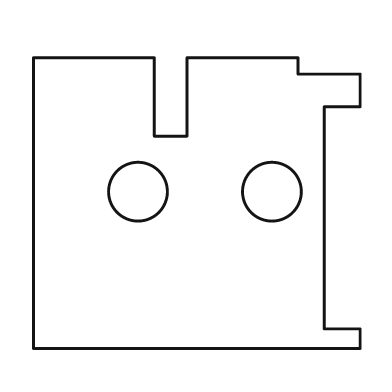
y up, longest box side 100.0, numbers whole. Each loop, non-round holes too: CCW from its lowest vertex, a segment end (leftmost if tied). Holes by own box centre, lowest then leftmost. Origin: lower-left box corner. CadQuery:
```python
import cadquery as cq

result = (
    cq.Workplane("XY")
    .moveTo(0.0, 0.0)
    .lineTo(100.0, 0.0)
    .lineTo(100.0, 6.0)
    .lineTo(89.0, 6.0)
    .lineTo(89.0, 74.0)
    .lineTo(100.0, 74.0)
    .lineTo(100.0, 84.0)
    .lineTo(81.0, 84.0)
    .lineTo(81.0, 89.0)
    .lineTo(47.0, 89.0)
    .lineTo(47.0, 65.0)
    .lineTo(37.0, 65.0)
    .lineTo(37.0, 89.0)
    .lineTo(0.0, 89.0)
    .close()
    .moveTo(32.0, 48.0)
    .circle(9.0)
    .moveTo(73.0, 48.0)
    .circle(9.0)
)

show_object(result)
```